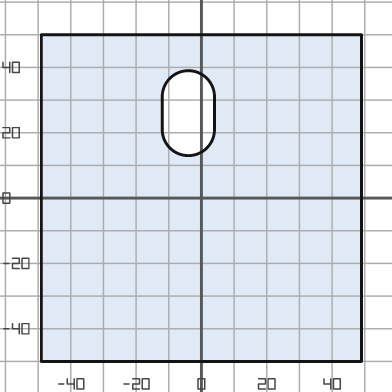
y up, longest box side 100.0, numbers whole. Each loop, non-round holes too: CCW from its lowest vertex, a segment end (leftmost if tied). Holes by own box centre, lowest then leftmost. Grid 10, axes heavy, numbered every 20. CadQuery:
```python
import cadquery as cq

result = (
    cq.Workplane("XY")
    .moveTo(-49.0, -50.0)
    .lineTo(49.0, -50.0)
    .lineTo(49.0, 50.0)
    .lineTo(-49.0, 50.0)
    .close()
    .moveTo(-12.0, 21.0)
    .threePointArc((-4.0, 13.0), (4.0, 21.0))
    .lineTo(4.0, 31.0)
    .threePointArc((-4.0, 39.0), (-12.0, 31.0))
    .close()
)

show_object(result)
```